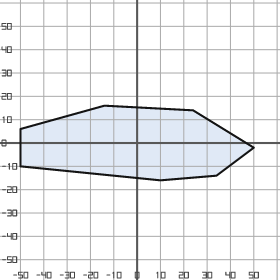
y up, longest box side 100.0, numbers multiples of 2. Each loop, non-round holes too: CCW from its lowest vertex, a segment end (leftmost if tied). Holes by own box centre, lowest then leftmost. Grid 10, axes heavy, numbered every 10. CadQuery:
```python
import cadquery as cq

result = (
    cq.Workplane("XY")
    .moveTo(10.0, -16.0)
    .lineTo(34.0, -14.0)
    .lineTo(50.0, -2.0)
    .lineTo(24.0, 14.0)
    .lineTo(-14.0, 16.0)
    .lineTo(-50.0, 6.0)
    .lineTo(-50.0, -10.0)
    .close()
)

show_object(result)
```